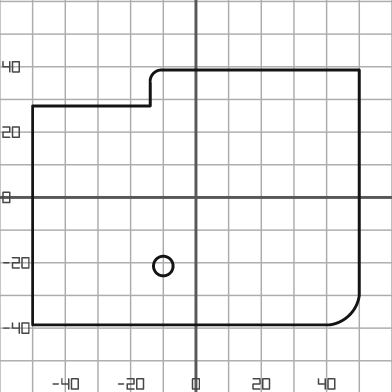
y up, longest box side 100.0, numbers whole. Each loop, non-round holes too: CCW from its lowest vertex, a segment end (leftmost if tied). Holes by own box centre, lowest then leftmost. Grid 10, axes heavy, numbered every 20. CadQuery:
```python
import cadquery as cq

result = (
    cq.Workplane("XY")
    .moveTo(-50.0, -39.0)
    .lineTo(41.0, -39.0)
    .threePointArc((47.0, -36.0), (50.0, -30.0))
    .lineTo(50.0, 39.0)
    .lineTo(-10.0, 39.0)
    .threePointArc((-13.0, 38.0), (-14.0, 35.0))
    .lineTo(-14.0, 28.0)
    .lineTo(-50.0, 28.0)
    .close()
    .moveTo(-10.0, -21.0)
    .circle(3.0)
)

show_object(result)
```